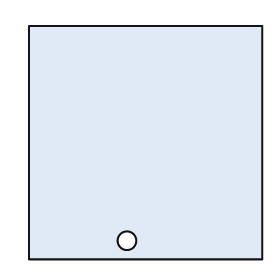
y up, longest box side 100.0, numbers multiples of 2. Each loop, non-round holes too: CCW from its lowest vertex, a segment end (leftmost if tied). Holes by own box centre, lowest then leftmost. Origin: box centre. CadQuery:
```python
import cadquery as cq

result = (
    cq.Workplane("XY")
    .moveTo(-50.0, -50.0)
    .lineTo(50.0, -50.0)
    .lineTo(50.0, 50.0)
    .lineTo(-50.0, 50.0)
    .close()
    .moveTo(-8.0, -42.0)
    .circle(4.0)
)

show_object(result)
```